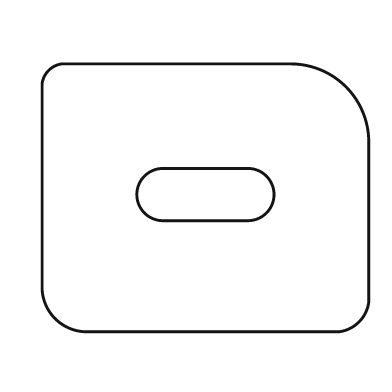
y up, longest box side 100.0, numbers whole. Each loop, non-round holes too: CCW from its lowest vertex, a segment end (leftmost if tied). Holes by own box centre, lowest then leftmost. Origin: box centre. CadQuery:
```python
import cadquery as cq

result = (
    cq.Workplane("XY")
    .moveTo(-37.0, -41.0)
    .lineTo(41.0, -41.0)
    .threePointArc((47.0, -38.0), (50.0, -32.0))
    .lineTo(50.0, 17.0)
    .threePointArc((43.0, 34.0), (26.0, 41.0))
    .lineTo(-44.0, 41.0)
    .threePointArc((-48.0, 39.0), (-50.0, 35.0))
    .lineTo(-50.0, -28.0)
    .threePointArc((-46.0, -37.0), (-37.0, -41.0))
    .close()
    .moveTo(-13.0, -7.0)
    .lineTo(13.0, -7.0)
    .threePointArc((21.0, 1.0), (13.0, 9.0))
    .lineTo(-13.0, 9.0)
    .threePointArc((-21.0, 1.0), (-13.0, -7.0))
    .close()
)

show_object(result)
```